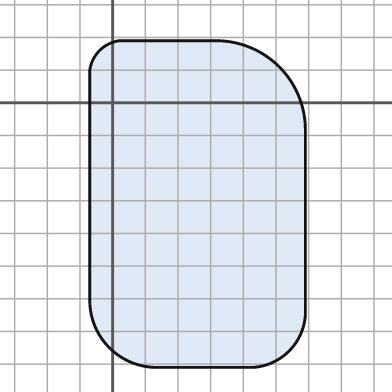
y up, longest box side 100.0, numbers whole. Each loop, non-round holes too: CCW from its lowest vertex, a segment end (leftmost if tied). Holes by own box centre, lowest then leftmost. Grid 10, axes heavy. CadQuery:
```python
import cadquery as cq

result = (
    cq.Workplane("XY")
    .moveTo(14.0, -81.0)
    .lineTo(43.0, -81.0)
    .threePointArc((54.0, -76.0), (59.0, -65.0))
    .lineTo(59.0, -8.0)
    .threePointArc((51.0, 11.0), (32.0, 19.0))
    .lineTo(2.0, 19.0)
    .threePointArc((-4.0, 16.0), (-7.0, 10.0))
    .lineTo(-7.0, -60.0)
    .threePointArc((-1.0, -75.0), (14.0, -81.0))
    .close()
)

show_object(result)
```